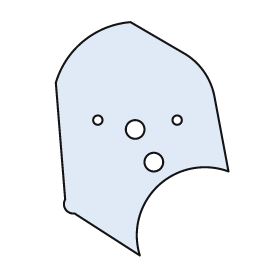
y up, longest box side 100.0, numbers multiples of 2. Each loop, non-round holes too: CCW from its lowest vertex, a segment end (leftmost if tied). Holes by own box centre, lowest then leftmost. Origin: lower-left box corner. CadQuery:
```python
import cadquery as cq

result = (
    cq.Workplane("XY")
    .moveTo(36.0, 0.0)
    .threePointArc((44.0, 30.0), (74.0, 36.0))
    .lineTo(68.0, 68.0)
    .threePointArc((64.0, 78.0), (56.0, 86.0))
    .lineTo(32.0, 100.0)
    .threePointArc((12.0, 92.0), (0.0, 74.0))
    .lineTo(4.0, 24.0)
    .threePointArc((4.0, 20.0), (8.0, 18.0))
    .close()
    .moveTo(42.0, 40.0)
    .circle(4.0)
    .moveTo(34.0, 54.0)
    .circle(4.0)
    .moveTo(18.0, 58.0)
    .circle(2.0)
    .moveTo(52.0, 58.0)
    .circle(2.0)
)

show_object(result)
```